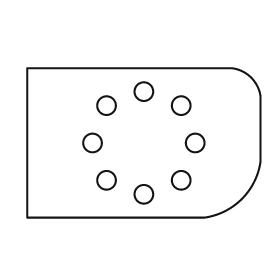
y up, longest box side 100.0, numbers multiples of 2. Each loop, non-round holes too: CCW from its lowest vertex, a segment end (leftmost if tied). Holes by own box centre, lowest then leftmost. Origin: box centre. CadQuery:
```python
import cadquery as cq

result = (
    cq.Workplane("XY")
    .moveTo(-50.0, -32.0)
    .lineTo(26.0, -32.0)
    .threePointArc((42.0, -24.0), (50.0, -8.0))
    .lineTo(50.0, 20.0)
    .threePointArc((46.0, 28.0), (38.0, 32.0))
    .lineTo(-50.0, 32.0)
    .close()
    .moveTo(0.0, -22.0)
    .circle(4.0)
    .moveTo(-16.0, -16.0)
    .circle(4.0)
    .moveTo(16.0, -16.0)
    .circle(4.0)
    .moveTo(-22.0, 0.0)
    .circle(4.0)
    .moveTo(22.0, 0.0)
    .circle(4.0)
    .moveTo(-16.0, 16.0)
    .circle(4.0)
    .moveTo(16.0, 16.0)
    .circle(4.0)
    .moveTo(0.0, 22.0)
    .circle(4.0)
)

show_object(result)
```